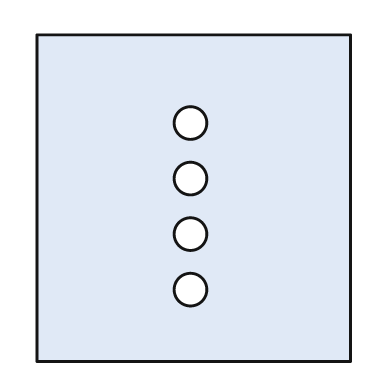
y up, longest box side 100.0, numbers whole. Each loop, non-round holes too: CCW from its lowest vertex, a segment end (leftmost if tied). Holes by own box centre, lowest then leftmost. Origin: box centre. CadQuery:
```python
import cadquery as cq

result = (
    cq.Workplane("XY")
    .moveTo(-48.0, -50.0)
    .lineTo(48.0, -50.0)
    .lineTo(48.0, 50.0)
    .lineTo(-48.0, 50.0)
    .close()
    .moveTo(-1.0, -28.0)
    .circle(5.0)
    .moveTo(-1.0, -11.0)
    .circle(5.0)
    .moveTo(-1.0, 6.0)
    .circle(5.0)
    .moveTo(-1.0, 23.0)
    .circle(5.0)
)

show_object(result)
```